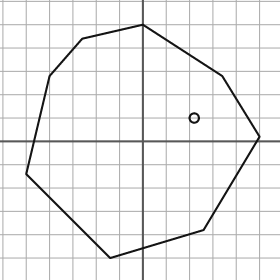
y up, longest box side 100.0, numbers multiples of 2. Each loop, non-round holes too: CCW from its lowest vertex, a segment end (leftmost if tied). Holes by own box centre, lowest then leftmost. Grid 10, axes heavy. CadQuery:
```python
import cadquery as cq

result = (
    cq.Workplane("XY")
    .moveTo(-14.0, -50.0)
    .lineTo(26.0, -38.0)
    .lineTo(50.0, 2.0)
    .lineTo(34.0, 28.0)
    .lineTo(0.0, 50.0)
    .lineTo(-26.0, 44.0)
    .lineTo(-40.0, 28.0)
    .lineTo(-50.0, -14.0)
    .close()
    .moveTo(22.0, 10.0)
    .circle(2.0)
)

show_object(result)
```